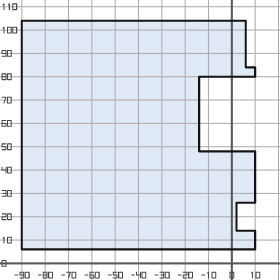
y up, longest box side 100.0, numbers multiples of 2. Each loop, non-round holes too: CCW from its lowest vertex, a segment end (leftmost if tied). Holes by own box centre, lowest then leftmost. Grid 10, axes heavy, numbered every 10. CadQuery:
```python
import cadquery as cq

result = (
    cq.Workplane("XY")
    .moveTo(-90.0, 6.0)
    .lineTo(10.0, 6.0)
    .lineTo(10.0, 14.0)
    .lineTo(2.0, 14.0)
    .lineTo(2.0, 26.0)
    .lineTo(10.0, 26.0)
    .lineTo(10.0, 48.0)
    .lineTo(-14.0, 48.0)
    .lineTo(-14.0, 80.0)
    .lineTo(10.0, 80.0)
    .lineTo(10.0, 84.0)
    .lineTo(6.0, 84.0)
    .lineTo(6.0, 104.0)
    .lineTo(-90.0, 104.0)
    .close()
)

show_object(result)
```